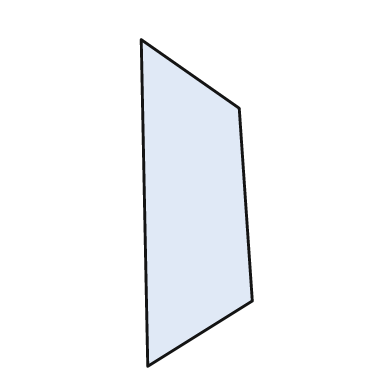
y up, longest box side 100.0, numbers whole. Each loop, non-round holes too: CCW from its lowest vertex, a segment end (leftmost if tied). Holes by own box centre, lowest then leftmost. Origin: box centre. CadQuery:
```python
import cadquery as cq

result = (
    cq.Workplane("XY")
    .moveTo(-15.0, -50.0)
    .lineTo(17.0, -30.0)
    .lineTo(13.0, 29.0)
    .lineTo(-17.0, 50.0)
    .close()
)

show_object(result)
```